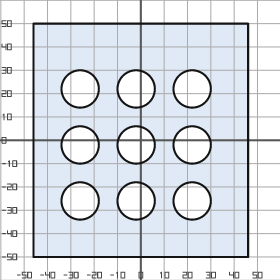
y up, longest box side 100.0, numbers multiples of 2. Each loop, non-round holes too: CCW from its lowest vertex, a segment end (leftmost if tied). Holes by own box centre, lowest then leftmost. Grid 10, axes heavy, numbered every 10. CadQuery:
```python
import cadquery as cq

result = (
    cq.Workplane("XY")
    .moveTo(-46.0, -50.0)
    .lineTo(46.0, -50.0)
    .lineTo(46.0, 50.0)
    .lineTo(-46.0, 50.0)
    .close()
    .moveTo(-26.0, -26.0)
    .circle(8.0)
    .moveTo(-2.0, -26.0)
    .circle(8.0)
    .moveTo(22.0, -26.0)
    .circle(8.0)
    .moveTo(-26.0, -2.0)
    .circle(8.0)
    .moveTo(-2.0, -2.0)
    .circle(8.0)
    .moveTo(22.0, -2.0)
    .circle(8.0)
    .moveTo(-26.0, 22.0)
    .circle(8.0)
    .moveTo(-2.0, 22.0)
    .circle(8.0)
    .moveTo(22.0, 22.0)
    .circle(8.0)
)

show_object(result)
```